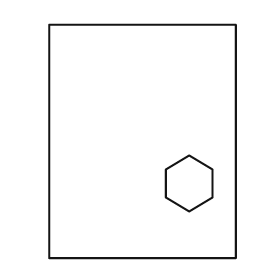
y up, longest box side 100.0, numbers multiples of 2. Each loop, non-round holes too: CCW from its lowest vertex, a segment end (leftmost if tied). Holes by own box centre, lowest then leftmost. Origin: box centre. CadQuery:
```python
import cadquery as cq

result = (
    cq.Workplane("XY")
    .moveTo(-40.0, -50.0)
    .lineTo(40.0, -50.0)
    .lineTo(40.0, 50.0)
    .lineTo(-40.0, 50.0)
    .close()
    .moveTo(20.0, -30.0)
    .lineTo(30.0, -24.0)
    .lineTo(30.0, -12.0)
    .lineTo(20.0, -6.0)
    .lineTo(10.0, -12.0)
    .lineTo(10.0, -24.0)
    .close()
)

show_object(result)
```